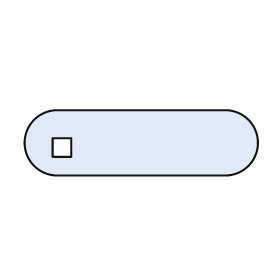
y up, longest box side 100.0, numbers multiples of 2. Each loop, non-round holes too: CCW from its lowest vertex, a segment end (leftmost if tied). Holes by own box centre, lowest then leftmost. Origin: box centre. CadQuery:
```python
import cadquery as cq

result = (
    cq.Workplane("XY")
    .moveTo(-36.0, -14.0)
    .lineTo(36.0, -14.0)
    .threePointArc((50.0, 0.0), (36.0, 14.0))
    .lineTo(-36.0, 14.0)
    .threePointArc((-50.0, 0.0), (-36.0, -14.0))
    .close()
    .moveTo(-38.0, -6.0)
    .lineTo(-30.0, -6.0)
    .lineTo(-30.0, 2.0)
    .lineTo(-38.0, 2.0)
    .close()
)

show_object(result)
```